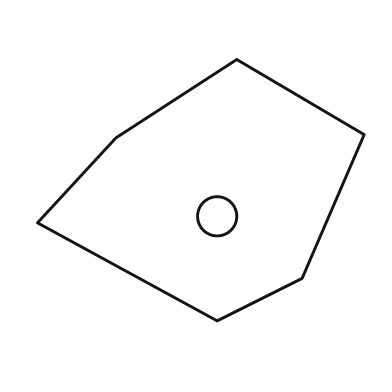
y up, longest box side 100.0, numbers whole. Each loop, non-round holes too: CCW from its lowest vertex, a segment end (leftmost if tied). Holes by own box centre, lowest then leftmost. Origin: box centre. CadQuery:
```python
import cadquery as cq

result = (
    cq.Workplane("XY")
    .moveTo(5.0, -40.0)
    .lineTo(31.0, -27.0)
    .lineTo(50.0, 17.0)
    .lineTo(11.0, 40.0)
    .lineTo(-26.0, 16.0)
    .lineTo(-50.0, -10.0)
    .close()
    .moveTo(5.0, -8.0)
    .circle(6.0)
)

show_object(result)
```